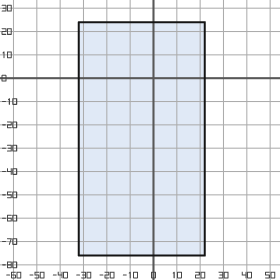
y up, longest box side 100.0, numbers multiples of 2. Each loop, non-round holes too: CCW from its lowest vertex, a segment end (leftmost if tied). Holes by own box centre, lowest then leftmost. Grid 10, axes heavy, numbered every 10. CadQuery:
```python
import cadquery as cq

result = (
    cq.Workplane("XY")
    .moveTo(-32.0, -76.0)
    .lineTo(22.0, -76.0)
    .lineTo(22.0, 24.0)
    .lineTo(-32.0, 24.0)
    .close()
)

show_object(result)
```